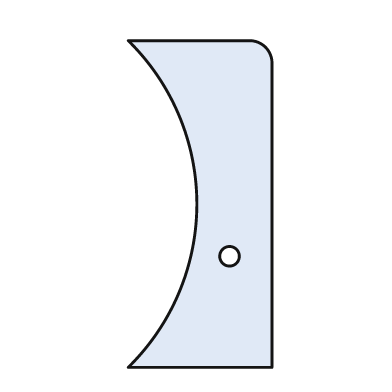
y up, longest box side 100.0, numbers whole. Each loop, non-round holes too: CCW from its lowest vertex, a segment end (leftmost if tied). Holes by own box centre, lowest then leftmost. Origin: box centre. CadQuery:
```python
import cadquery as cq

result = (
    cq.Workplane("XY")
    .moveTo(-22.0, -50.0)
    .lineTo(22.0, -50.0)
    .lineTo(22.0, 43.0)
    .threePointArc((20.0, 48.0), (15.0, 50.0))
    .lineTo(-22.0, 50.0)
    .threePointArc((-1.0, 0.0), (-22.0, -50.0))
    .close()
    .moveTo(9.0, -16.0)
    .circle(3.0)
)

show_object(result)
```